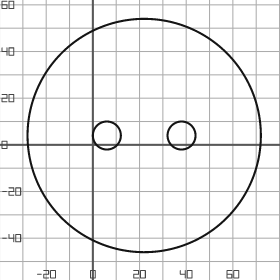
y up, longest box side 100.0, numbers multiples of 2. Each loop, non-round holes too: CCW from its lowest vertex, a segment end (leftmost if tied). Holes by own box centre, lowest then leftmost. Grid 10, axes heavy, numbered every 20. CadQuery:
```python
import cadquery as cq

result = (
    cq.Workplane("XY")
    .moveTo(22.0, 4.0)
    .circle(50.0)
    .moveTo(6.0, 4.0)
    .circle(6.0)
    .moveTo(38.0, 4.0)
    .circle(6.0)
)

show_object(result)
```